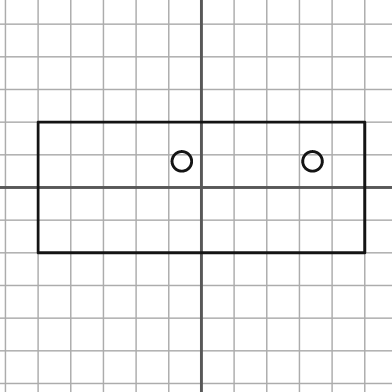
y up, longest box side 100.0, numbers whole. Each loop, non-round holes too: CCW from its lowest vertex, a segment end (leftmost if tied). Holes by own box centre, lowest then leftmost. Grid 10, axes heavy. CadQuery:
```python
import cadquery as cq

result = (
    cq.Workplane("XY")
    .moveTo(-50.0, -20.0)
    .lineTo(50.0, -20.0)
    .lineTo(50.0, 20.0)
    .lineTo(-50.0, 20.0)
    .close()
    .moveTo(-6.0, 8.0)
    .circle(3.0)
    .moveTo(34.0, 8.0)
    .circle(3.0)
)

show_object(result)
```